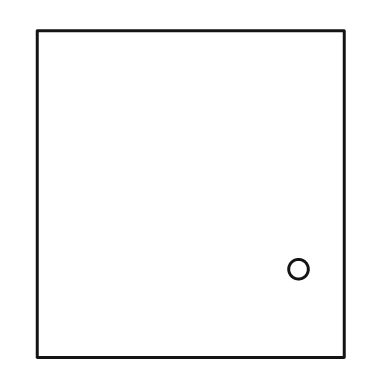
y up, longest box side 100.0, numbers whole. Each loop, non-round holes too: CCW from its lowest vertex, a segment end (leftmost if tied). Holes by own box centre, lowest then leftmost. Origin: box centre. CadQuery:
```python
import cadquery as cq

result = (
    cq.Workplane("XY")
    .moveTo(-47.0, -50.0)
    .lineTo(47.0, -50.0)
    .lineTo(47.0, 50.0)
    .lineTo(-47.0, 50.0)
    .close()
    .moveTo(33.0, -23.0)
    .circle(3.0)
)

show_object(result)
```